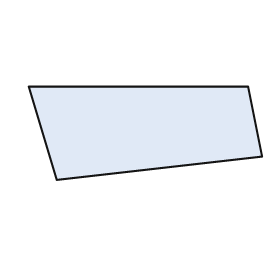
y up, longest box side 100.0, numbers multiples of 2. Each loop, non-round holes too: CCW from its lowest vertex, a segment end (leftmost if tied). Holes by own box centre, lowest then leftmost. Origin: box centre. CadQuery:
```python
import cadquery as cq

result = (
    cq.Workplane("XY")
    .moveTo(-38.0, -20.0)
    .lineTo(50.0, -10.0)
    .lineTo(44.0, 20.0)
    .lineTo(-50.0, 20.0)
    .close()
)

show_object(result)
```